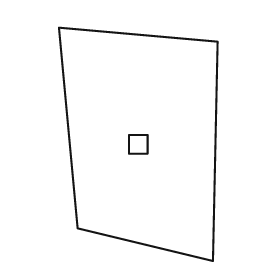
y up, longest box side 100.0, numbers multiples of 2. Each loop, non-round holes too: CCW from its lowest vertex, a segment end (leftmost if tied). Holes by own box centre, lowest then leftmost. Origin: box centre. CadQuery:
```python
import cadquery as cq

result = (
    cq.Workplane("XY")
    .moveTo(32.0, -50.0)
    .lineTo(34.0, 44.0)
    .lineTo(-34.0, 50.0)
    .lineTo(-26.0, -36.0)
    .close()
    .moveTo(-4.0, -4.0)
    .lineTo(4.0, -4.0)
    .lineTo(4.0, 4.0)
    .lineTo(-4.0, 4.0)
    .close()
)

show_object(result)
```